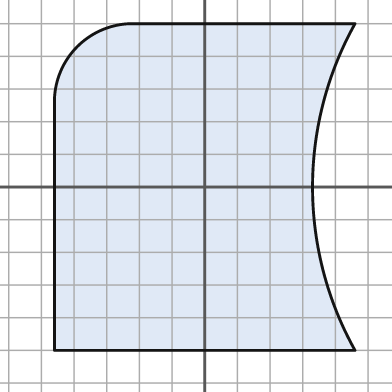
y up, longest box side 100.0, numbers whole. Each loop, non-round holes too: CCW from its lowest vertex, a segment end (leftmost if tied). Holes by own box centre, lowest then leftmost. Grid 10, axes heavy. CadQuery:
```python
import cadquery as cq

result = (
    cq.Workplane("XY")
    .moveTo(-46.0, -50.0)
    .lineTo(46.0, -50.0)
    .threePointArc((33.0, 0.0), (46.0, 50.0))
    .lineTo(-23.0, 50.0)
    .threePointArc((-39.0, 43.0), (-46.0, 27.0))
    .close()
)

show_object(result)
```